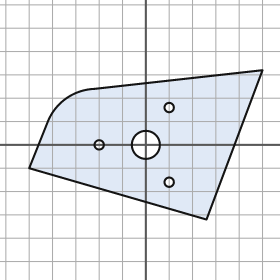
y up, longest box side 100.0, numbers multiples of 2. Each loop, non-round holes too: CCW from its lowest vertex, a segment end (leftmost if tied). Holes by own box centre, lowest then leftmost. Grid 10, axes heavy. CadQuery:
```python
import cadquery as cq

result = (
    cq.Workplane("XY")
    .moveTo(26.0, -32.0)
    .lineTo(50.0, 32.0)
    .lineTo(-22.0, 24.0)
    .threePointArc((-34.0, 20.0), (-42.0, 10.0))
    .lineTo(-50.0, -10.0)
    .close()
    .moveTo(10.0, -16.0)
    .circle(2.0)
    .moveTo(-20.0, 0.0)
    .circle(2.0)
    .moveTo(0.0, 0.0)
    .circle(6.0)
    .moveTo(10.0, 16.0)
    .circle(2.0)
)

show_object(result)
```